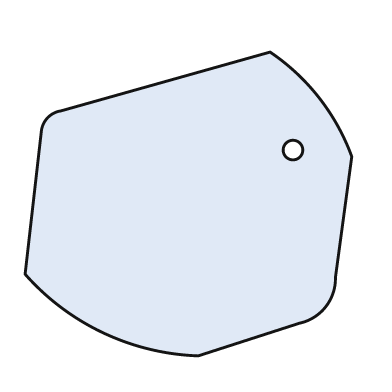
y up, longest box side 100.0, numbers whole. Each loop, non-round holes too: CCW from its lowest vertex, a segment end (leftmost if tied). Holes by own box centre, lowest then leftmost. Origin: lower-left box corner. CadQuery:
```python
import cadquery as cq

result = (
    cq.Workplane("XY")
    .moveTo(53.0, 0.0)
    .lineTo(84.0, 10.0)
    .threePointArc((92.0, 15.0), (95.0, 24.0))
    .lineTo(100.0, 61.0)
    .threePointArc((90.0, 79.0), (75.0, 93.0))
    .lineTo(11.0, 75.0)
    .threePointArc((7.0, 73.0), (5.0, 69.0))
    .lineTo(0.0, 25.0)
    .threePointArc((24.0, 7.0), (53.0, 0.0))
    .close()
    .moveTo(82.0, 63.0)
    .circle(3.0)
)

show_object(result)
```